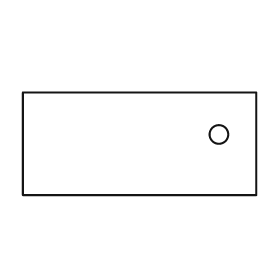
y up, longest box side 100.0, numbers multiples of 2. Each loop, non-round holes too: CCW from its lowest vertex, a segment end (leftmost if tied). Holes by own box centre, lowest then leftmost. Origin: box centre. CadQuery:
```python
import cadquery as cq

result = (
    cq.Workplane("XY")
    .moveTo(-50.0, -22.0)
    .lineTo(50.0, -22.0)
    .lineTo(50.0, 22.0)
    .lineTo(-50.0, 22.0)
    .close()
    .moveTo(34.0, 4.0)
    .circle(4.0)
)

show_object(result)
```